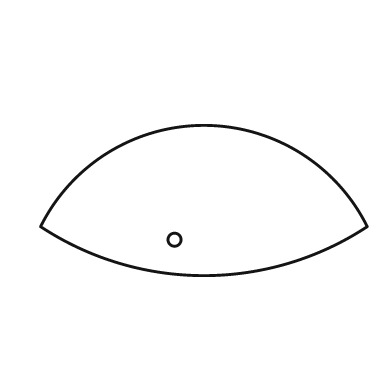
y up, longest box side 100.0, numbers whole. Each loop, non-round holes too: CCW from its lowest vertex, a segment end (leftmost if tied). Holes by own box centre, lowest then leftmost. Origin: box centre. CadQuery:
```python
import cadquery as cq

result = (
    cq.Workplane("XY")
    .moveTo(-50.0, -8.0)
    .threePointArc((0.0, -23.0), (50.0, -8.0))
    .threePointArc((0.0, 23.0), (-50.0, -8.0))
    .close()
    .moveTo(-9.0, -12.0)
    .circle(2.0)
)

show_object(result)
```